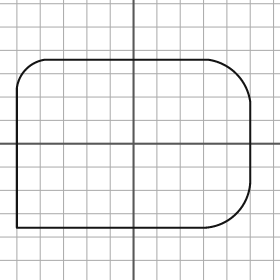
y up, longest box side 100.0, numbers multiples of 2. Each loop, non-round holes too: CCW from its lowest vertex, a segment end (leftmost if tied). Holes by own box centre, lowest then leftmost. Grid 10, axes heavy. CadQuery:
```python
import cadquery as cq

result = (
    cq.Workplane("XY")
    .moveTo(-50.0, -36.0)
    .lineTo(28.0, -36.0)
    .threePointArc((44.0, -30.0), (50.0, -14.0))
    .lineTo(50.0, 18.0)
    .threePointArc((44.0, 30.0), (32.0, 36.0))
    .lineTo(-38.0, 36.0)
    .threePointArc((-46.0, 32.0), (-50.0, 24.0))
    .close()
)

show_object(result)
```